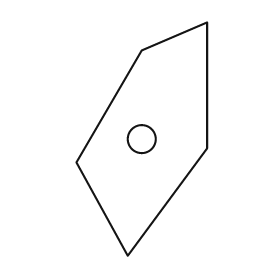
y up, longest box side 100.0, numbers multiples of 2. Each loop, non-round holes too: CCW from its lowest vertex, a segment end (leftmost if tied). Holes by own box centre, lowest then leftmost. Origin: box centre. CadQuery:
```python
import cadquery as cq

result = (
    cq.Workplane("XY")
    .moveTo(-6.0, -50.0)
    .lineTo(28.0, -4.0)
    .lineTo(28.0, 50.0)
    .lineTo(0.0, 38.0)
    .lineTo(-28.0, -10.0)
    .close()
    .moveTo(0.0, 0.0)
    .circle(6.0)
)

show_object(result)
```